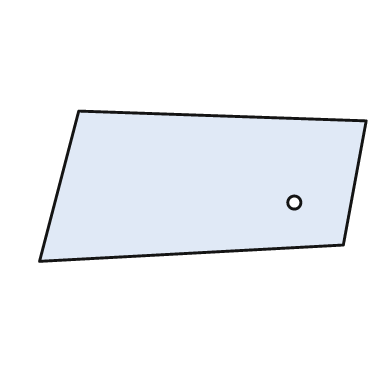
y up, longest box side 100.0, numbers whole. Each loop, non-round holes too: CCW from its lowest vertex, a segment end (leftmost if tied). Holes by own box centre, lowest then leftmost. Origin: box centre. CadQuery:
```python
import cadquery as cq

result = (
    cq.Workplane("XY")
    .moveTo(-50.0, -23.0)
    .lineTo(43.0, -18.0)
    .lineTo(50.0, 20.0)
    .lineTo(-38.0, 23.0)
    .close()
    .moveTo(28.0, -5.0)
    .circle(2.0)
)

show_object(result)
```